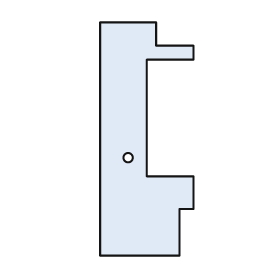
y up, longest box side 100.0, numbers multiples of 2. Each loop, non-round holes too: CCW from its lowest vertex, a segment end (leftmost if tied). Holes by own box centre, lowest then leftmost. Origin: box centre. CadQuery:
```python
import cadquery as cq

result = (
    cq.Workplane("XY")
    .moveTo(-20.0, -50.0)
    .lineTo(14.0, -50.0)
    .lineTo(14.0, -30.0)
    .lineTo(20.0, -30.0)
    .lineTo(20.0, -16.0)
    .lineTo(0.0, -16.0)
    .lineTo(0.0, 34.0)
    .lineTo(20.0, 34.0)
    .lineTo(20.0, 40.0)
    .lineTo(4.0, 40.0)
    .lineTo(4.0, 50.0)
    .lineTo(-20.0, 50.0)
    .close()
    .moveTo(-8.0, -8.0)
    .circle(2.0)
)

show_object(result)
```